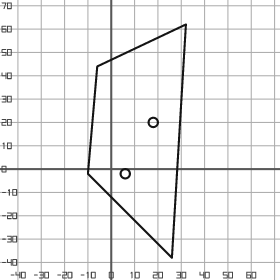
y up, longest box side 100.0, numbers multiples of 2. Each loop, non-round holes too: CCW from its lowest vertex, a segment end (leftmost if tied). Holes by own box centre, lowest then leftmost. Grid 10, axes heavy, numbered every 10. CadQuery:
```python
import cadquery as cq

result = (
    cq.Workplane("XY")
    .moveTo(26.0, -38.0)
    .lineTo(32.0, 62.0)
    .lineTo(-6.0, 44.0)
    .lineTo(-10.0, -2.0)
    .close()
    .moveTo(6.0, -2.0)
    .circle(2.0)
    .moveTo(18.0, 20.0)
    .circle(2.0)
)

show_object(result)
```